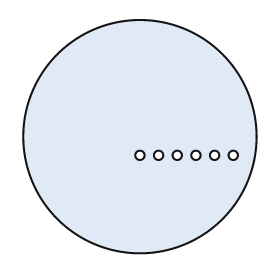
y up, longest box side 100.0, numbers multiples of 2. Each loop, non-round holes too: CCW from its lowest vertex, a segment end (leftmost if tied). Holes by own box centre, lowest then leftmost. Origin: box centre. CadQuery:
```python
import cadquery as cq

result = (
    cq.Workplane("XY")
    .moveTo(0.0, 0.0)
    .circle(50.0)
    .moveTo(0.0, -8.0)
    .circle(2.0)
    .moveTo(8.0, -8.0)
    .circle(2.0)
    .moveTo(16.0, -8.0)
    .circle(2.0)
    .moveTo(24.0, -8.0)
    .circle(2.0)
    .moveTo(32.0, -8.0)
    .circle(2.0)
    .moveTo(40.0, -8.0)
    .circle(2.0)
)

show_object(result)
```